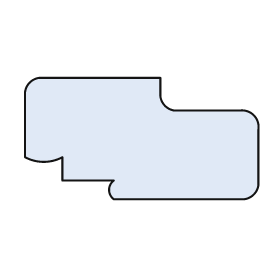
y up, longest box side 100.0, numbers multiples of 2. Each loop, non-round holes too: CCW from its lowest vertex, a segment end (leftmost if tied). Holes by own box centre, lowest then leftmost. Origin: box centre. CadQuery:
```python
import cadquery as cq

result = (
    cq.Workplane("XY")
    .moveTo(-12.0, -26.0)
    .lineTo(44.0, -26.0)
    .threePointArc((48.0, -24.0), (50.0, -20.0))
    .lineTo(50.0, 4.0)
    .threePointArc((48.0, 10.0), (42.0, 12.0))
    .lineTo(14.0, 12.0)
    .threePointArc((10.0, 14.0), (8.0, 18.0))
    .lineTo(8.0, 26.0)
    .lineTo(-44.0, 26.0)
    .threePointArc((-48.0, 24.0), (-50.0, 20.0))
    .lineTo(-50.0, -8.0)
    .threePointArc((-42.0, -10.0), (-34.0, -8.0))
    .lineTo(-34.0, -18.0)
    .lineTo(-12.0, -18.0)
    .threePointArc((-14.0, -22.0), (-12.0, -26.0))
    .close()
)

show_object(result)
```